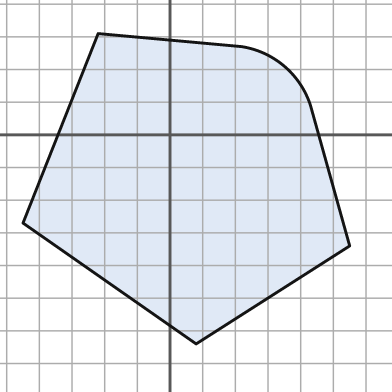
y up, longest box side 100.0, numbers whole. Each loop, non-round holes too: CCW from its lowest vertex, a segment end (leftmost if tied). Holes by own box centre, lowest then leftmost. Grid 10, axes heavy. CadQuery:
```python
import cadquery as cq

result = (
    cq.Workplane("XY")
    .moveTo(8.0, -64.0)
    .lineTo(55.0, -34.0)
    .lineTo(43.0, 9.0)
    .threePointArc((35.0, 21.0), (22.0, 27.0))
    .lineTo(-22.0, 31.0)
    .lineTo(-45.0, -27.0)
    .close()
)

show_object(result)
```